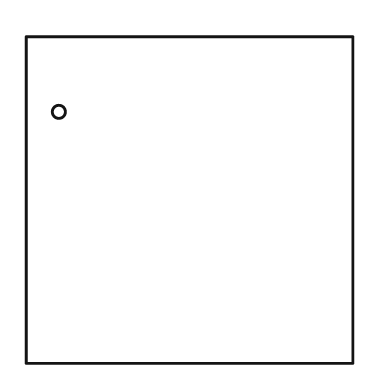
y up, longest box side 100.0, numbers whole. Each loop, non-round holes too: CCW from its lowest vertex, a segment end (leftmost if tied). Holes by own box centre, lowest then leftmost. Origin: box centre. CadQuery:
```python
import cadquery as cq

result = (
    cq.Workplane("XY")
    .moveTo(-50.0, -50.0)
    .lineTo(50.0, -50.0)
    .lineTo(50.0, 50.0)
    .lineTo(-50.0, 50.0)
    .close()
    .moveTo(-40.0, 27.0)
    .circle(2.0)
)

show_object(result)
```